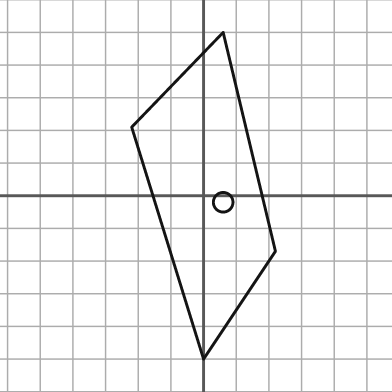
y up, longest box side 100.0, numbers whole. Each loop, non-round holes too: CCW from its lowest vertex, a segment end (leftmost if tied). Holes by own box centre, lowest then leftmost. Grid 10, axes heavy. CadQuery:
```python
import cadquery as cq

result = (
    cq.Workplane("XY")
    .moveTo(0.0, -50.0)
    .lineTo(22.0, -17.0)
    .lineTo(6.0, 50.0)
    .lineTo(-22.0, 21.0)
    .close()
    .moveTo(6.0, -2.0)
    .circle(3.0)
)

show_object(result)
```